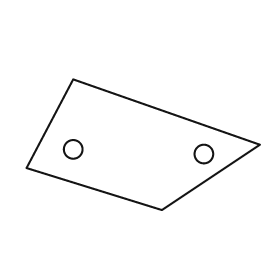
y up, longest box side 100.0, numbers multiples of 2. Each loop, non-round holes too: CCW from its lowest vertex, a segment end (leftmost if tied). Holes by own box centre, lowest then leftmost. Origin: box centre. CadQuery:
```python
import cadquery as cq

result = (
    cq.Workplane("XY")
    .moveTo(8.0, -28.0)
    .lineTo(50.0, 0.0)
    .lineTo(-30.0, 28.0)
    .lineTo(-50.0, -10.0)
    .close()
    .moveTo(26.0, -4.0)
    .circle(4.0)
    .moveTo(-30.0, -2.0)
    .circle(4.0)
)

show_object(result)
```